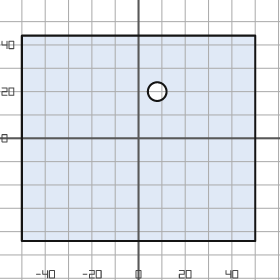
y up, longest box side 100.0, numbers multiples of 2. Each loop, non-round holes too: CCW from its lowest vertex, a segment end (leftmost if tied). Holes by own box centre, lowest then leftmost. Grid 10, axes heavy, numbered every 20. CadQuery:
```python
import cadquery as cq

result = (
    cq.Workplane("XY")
    .moveTo(-50.0, -44.0)
    .lineTo(50.0, -44.0)
    .lineTo(50.0, 44.0)
    .lineTo(-50.0, 44.0)
    .close()
    .moveTo(8.0, 20.0)
    .circle(4.0)
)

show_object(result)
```